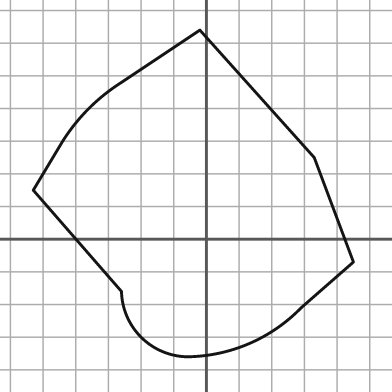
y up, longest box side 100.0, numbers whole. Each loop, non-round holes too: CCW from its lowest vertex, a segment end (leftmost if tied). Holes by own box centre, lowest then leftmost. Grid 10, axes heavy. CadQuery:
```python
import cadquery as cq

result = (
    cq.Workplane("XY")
    .moveTo(-6.0, -36.0)
    .threePointArc((13.0, -32.0), (29.0, -21.0))
    .lineTo(45.0, -7.0)
    .lineTo(33.0, 25.0)
    .lineTo(-2.0, 64.0)
    .lineTo(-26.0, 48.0)
    .threePointArc((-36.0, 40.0), (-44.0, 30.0))
    .lineTo(-53.0, 15.0)
    .lineTo(-26.0, -16.0)
    .threePointArc((-20.0, -30.0), (-6.0, -36.0))
    .close()
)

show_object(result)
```